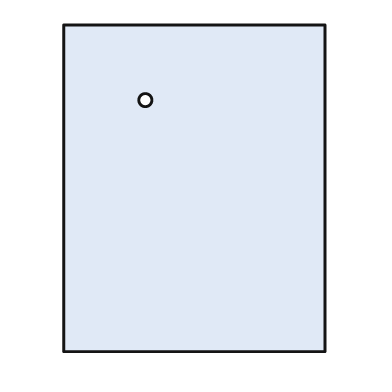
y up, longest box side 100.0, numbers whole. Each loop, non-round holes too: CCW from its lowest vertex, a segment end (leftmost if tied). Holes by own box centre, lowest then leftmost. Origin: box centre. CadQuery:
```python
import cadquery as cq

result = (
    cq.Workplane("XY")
    .moveTo(-40.0, -50.0)
    .lineTo(40.0, -50.0)
    .lineTo(40.0, 50.0)
    .lineTo(-40.0, 50.0)
    .close()
    .moveTo(-15.0, 27.0)
    .circle(2.0)
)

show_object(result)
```